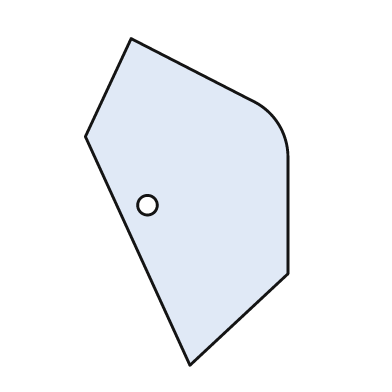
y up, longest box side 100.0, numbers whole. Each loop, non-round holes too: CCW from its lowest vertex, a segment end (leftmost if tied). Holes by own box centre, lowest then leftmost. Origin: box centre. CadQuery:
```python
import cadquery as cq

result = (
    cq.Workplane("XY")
    .moveTo(1.0, -50.0)
    .lineTo(31.0, -22.0)
    .lineTo(31.0, 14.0)
    .threePointArc((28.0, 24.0), (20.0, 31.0))
    .lineTo(-17.0, 50.0)
    .lineTo(-31.0, 20.0)
    .close()
    .moveTo(-12.0, -1.0)
    .circle(3.0)
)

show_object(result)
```